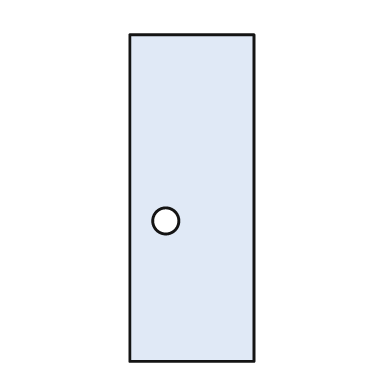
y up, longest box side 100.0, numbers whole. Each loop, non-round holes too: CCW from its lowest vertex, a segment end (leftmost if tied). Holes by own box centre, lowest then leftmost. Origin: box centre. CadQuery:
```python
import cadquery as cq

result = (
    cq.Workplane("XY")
    .moveTo(-19.0, -50.0)
    .lineTo(19.0, -50.0)
    .lineTo(19.0, 50.0)
    .lineTo(-19.0, 50.0)
    .close()
    .moveTo(-8.0, -7.0)
    .circle(4.0)
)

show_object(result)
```